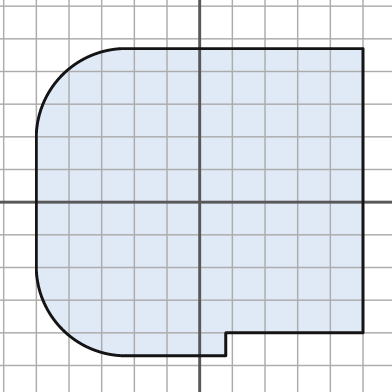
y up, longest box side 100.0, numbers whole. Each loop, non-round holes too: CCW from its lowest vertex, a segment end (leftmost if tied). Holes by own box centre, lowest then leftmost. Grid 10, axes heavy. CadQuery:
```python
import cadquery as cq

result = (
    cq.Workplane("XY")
    .moveTo(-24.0, -47.0)
    .lineTo(8.0, -47.0)
    .lineTo(8.0, -40.0)
    .lineTo(50.0, -40.0)
    .lineTo(50.0, 47.0)
    .lineTo(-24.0, 47.0)
    .threePointArc((-42.0, 39.0), (-50.0, 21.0))
    .lineTo(-50.0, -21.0)
    .threePointArc((-42.0, -39.0), (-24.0, -47.0))
    .close()
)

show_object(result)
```